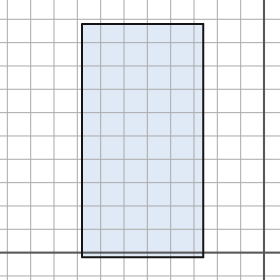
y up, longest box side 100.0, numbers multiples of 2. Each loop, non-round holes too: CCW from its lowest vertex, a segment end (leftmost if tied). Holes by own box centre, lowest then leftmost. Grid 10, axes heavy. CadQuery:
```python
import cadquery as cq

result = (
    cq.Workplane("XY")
    .moveTo(-78.0, -2.0)
    .lineTo(-26.0, -2.0)
    .lineTo(-26.0, 98.0)
    .lineTo(-78.0, 98.0)
    .close()
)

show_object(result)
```